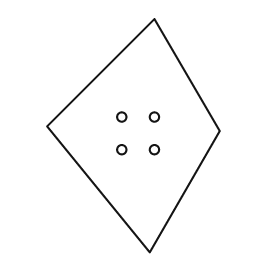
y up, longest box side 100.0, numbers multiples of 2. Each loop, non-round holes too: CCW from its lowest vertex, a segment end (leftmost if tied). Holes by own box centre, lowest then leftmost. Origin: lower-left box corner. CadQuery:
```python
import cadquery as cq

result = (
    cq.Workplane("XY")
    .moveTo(44.0, 0.0)
    .lineTo(74.0, 52.0)
    .lineTo(46.0, 100.0)
    .lineTo(0.0, 54.0)
    .close()
    .moveTo(32.0, 44.0)
    .circle(2.0)
    .moveTo(46.0, 44.0)
    .circle(2.0)
    .moveTo(32.0, 58.0)
    .circle(2.0)
    .moveTo(46.0, 58.0)
    .circle(2.0)
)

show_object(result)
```